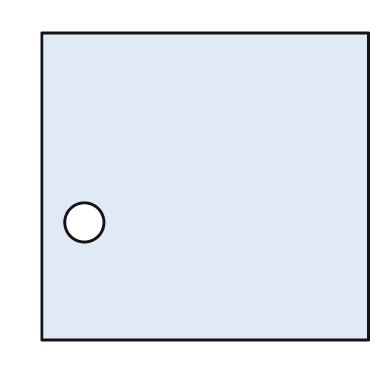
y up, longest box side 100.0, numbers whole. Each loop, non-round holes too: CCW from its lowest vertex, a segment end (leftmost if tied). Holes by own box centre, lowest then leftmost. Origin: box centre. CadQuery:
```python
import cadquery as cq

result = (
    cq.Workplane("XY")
    .moveTo(-50.0, -47.0)
    .lineTo(50.0, -47.0)
    .lineTo(50.0, 47.0)
    .lineTo(-50.0, 47.0)
    .close()
    .moveTo(-37.0, -11.0)
    .circle(6.0)
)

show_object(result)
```